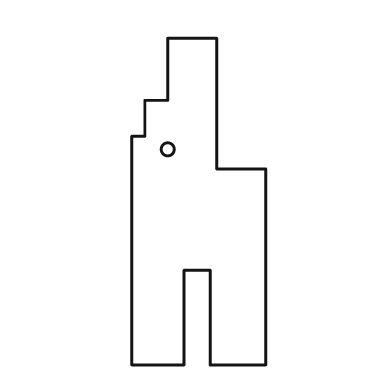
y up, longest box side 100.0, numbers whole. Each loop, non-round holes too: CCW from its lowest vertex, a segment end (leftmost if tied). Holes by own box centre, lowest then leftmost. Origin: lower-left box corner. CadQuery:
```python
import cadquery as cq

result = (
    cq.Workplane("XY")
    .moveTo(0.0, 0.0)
    .lineTo(16.0, 0.0)
    .lineTo(16.0, 29.0)
    .lineTo(24.0, 29.0)
    .lineTo(24.0, 0.0)
    .lineTo(41.0, 0.0)
    .lineTo(41.0, 60.0)
    .lineTo(26.0, 60.0)
    .lineTo(26.0, 100.0)
    .lineTo(11.0, 100.0)
    .lineTo(11.0, 81.0)
    .lineTo(4.0, 81.0)
    .lineTo(4.0, 70.0)
    .lineTo(0.0, 70.0)
    .close()
    .moveTo(11.0, 66.0)
    .circle(2.0)
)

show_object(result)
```